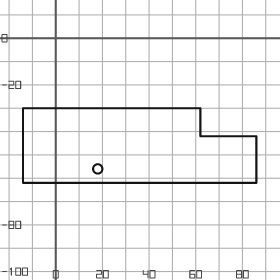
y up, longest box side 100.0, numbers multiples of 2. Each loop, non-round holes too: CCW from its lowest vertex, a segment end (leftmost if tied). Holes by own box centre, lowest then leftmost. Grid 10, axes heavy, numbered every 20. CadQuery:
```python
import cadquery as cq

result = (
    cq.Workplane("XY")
    .moveTo(-14.0, -62.0)
    .lineTo(86.0, -62.0)
    .lineTo(86.0, -42.0)
    .lineTo(62.0, -42.0)
    .lineTo(62.0, -30.0)
    .lineTo(-14.0, -30.0)
    .close()
    .moveTo(18.0, -56.0)
    .circle(2.0)
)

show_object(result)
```